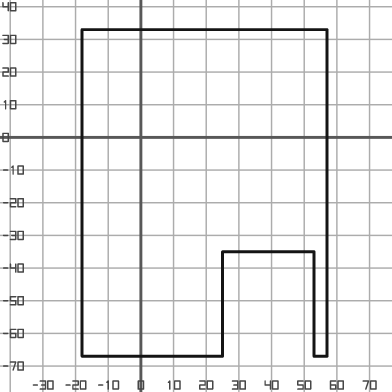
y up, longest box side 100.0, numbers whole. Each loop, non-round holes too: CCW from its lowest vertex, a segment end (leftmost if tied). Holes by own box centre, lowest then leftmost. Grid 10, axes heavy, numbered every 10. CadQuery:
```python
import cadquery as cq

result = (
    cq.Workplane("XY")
    .moveTo(-18.0, -67.0)
    .lineTo(25.0, -67.0)
    .lineTo(25.0, -35.0)
    .lineTo(53.0, -35.0)
    .lineTo(53.0, -67.0)
    .lineTo(57.0, -67.0)
    .lineTo(57.0, 33.0)
    .lineTo(-18.0, 33.0)
    .close()
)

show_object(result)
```